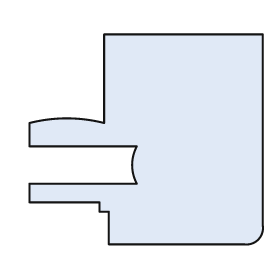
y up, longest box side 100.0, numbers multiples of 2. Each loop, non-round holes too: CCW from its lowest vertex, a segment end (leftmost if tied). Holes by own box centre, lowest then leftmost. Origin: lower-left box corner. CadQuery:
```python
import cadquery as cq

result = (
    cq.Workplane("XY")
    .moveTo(34.0, 0.0)
    .lineTo(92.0, 0.0)
    .threePointArc((98.0, 2.0), (100.0, 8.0))
    .lineTo(100.0, 90.0)
    .lineTo(32.0, 90.0)
    .lineTo(32.0, 52.0)
    .threePointArc((16.0, 54.0), (0.0, 52.0))
    .lineTo(0.0, 42.0)
    .lineTo(46.0, 42.0)
    .threePointArc((44.0, 34.0), (46.0, 26.0))
    .lineTo(0.0, 26.0)
    .lineTo(0.0, 18.0)
    .lineTo(30.0, 18.0)
    .lineTo(30.0, 14.0)
    .lineTo(34.0, 14.0)
    .close()
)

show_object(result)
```